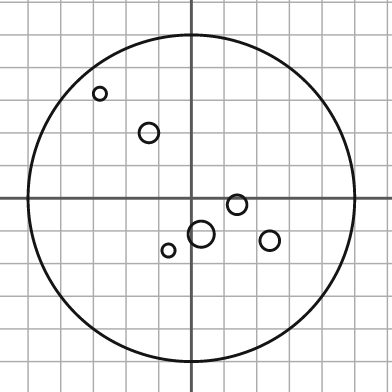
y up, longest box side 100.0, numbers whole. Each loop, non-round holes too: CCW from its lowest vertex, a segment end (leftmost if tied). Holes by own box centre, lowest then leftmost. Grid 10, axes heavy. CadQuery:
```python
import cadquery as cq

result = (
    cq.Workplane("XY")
    .moveTo(0.0, 0.0)
    .circle(50.0)
    .moveTo(-7.0, -16.0)
    .circle(2.0)
    .moveTo(24.0, -13.0)
    .circle(3.0)
    .moveTo(3.0, -11.0)
    .circle(4.0)
    .moveTo(14.0, -2.0)
    .circle(3.0)
    .moveTo(-13.0, 20.0)
    .circle(3.0)
    .moveTo(-28.0, 32.0)
    .circle(2.0)
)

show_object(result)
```